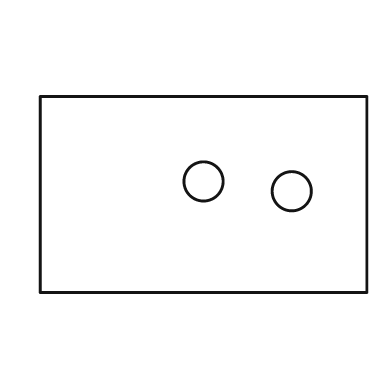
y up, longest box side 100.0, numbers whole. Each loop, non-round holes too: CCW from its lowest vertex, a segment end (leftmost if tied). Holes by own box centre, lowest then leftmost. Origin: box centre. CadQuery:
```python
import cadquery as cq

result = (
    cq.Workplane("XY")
    .moveTo(-50.0, -30.0)
    .lineTo(50.0, -30.0)
    .lineTo(50.0, 30.0)
    .lineTo(-50.0, 30.0)
    .close()
    .moveTo(27.0, 1.0)
    .circle(6.0)
    .moveTo(0.0, 4.0)
    .circle(6.0)
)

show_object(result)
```